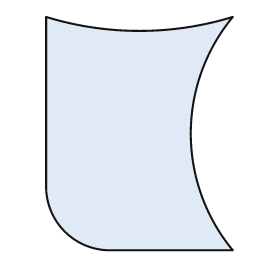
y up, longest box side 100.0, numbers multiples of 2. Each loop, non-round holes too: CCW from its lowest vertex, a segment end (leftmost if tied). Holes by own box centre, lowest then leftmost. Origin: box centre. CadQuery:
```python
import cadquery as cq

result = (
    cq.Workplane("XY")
    .moveTo(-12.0, -50.0)
    .lineTo(40.0, -50.0)
    .threePointArc((22.0, 0.0), (40.0, 50.0))
    .threePointArc((0.0, 44.0), (-40.0, 50.0))
    .lineTo(-40.0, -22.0)
    .threePointArc((-32.0, -42.0), (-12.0, -50.0))
    .close()
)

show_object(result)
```